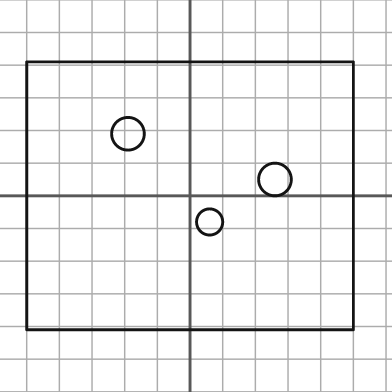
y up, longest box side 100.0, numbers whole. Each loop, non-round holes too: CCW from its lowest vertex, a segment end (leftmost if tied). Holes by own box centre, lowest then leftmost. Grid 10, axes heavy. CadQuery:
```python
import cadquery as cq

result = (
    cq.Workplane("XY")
    .moveTo(-50.0, -41.0)
    .lineTo(50.0, -41.0)
    .lineTo(50.0, 41.0)
    .lineTo(-50.0, 41.0)
    .close()
    .moveTo(6.0, -8.0)
    .circle(4.0)
    .moveTo(26.0, 5.0)
    .circle(5.0)
    .moveTo(-19.0, 19.0)
    .circle(5.0)
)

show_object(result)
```